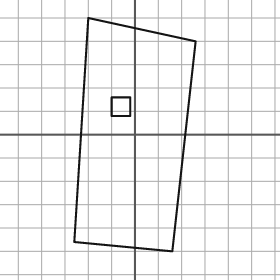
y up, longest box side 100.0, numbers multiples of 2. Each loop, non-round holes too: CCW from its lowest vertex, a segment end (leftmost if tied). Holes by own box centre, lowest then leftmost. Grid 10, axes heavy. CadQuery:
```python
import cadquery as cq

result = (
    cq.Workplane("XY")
    .moveTo(16.0, -50.0)
    .lineTo(26.0, 40.0)
    .lineTo(-20.0, 50.0)
    .lineTo(-26.0, -46.0)
    .close()
    .moveTo(-10.0, 8.0)
    .lineTo(-2.0, 8.0)
    .lineTo(-2.0, 16.0)
    .lineTo(-10.0, 16.0)
    .close()
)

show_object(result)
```